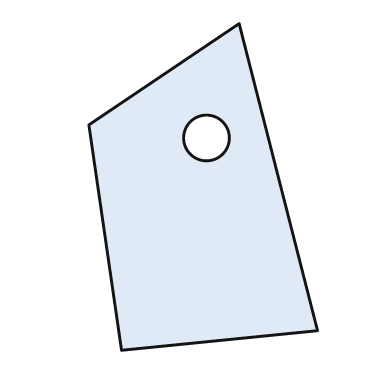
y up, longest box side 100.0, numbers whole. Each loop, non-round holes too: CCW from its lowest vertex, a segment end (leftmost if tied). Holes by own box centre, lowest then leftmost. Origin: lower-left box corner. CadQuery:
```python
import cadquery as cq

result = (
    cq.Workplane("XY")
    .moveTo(10.0, 0.0)
    .lineTo(70.0, 6.0)
    .lineTo(46.0, 100.0)
    .lineTo(0.0, 69.0)
    .close()
    .moveTo(36.0, 65.0)
    .circle(7.0)
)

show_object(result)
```